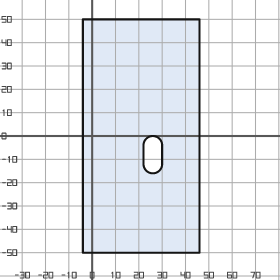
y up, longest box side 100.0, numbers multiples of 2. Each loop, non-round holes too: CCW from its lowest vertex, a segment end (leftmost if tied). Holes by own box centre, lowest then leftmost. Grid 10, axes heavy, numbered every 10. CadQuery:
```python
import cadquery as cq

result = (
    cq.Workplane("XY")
    .moveTo(-4.0, -50.0)
    .lineTo(46.0, -50.0)
    .lineTo(46.0, 50.0)
    .lineTo(-4.0, 50.0)
    .close()
    .moveTo(22.0, -12.0)
    .threePointArc((26.0, -16.0), (30.0, -12.0))
    .lineTo(30.0, -4.0)
    .threePointArc((26.0, 0.0), (22.0, -4.0))
    .close()
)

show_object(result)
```